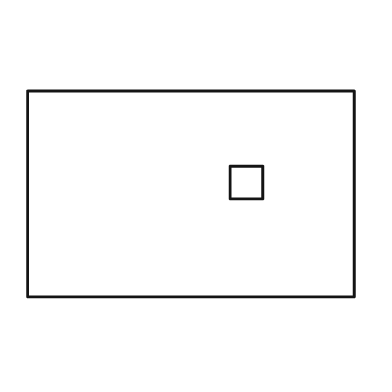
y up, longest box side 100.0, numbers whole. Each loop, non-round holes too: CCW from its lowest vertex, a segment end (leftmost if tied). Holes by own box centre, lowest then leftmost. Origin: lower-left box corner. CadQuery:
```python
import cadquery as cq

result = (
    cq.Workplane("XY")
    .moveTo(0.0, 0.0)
    .lineTo(100.0, 0.0)
    .lineTo(100.0, 63.0)
    .lineTo(0.0, 63.0)
    .close()
    .moveTo(62.0, 30.0)
    .lineTo(72.0, 30.0)
    .lineTo(72.0, 40.0)
    .lineTo(62.0, 40.0)
    .close()
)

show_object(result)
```